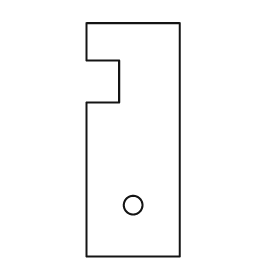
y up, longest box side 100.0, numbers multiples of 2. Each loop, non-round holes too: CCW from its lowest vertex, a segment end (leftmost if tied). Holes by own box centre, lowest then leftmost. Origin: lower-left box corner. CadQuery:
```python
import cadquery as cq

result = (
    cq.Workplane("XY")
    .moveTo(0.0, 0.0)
    .lineTo(40.0, 0.0)
    .lineTo(40.0, 100.0)
    .lineTo(0.0, 100.0)
    .lineTo(0.0, 84.0)
    .lineTo(14.0, 84.0)
    .lineTo(14.0, 66.0)
    .lineTo(0.0, 66.0)
    .close()
    .moveTo(20.0, 22.0)
    .circle(4.0)
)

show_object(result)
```